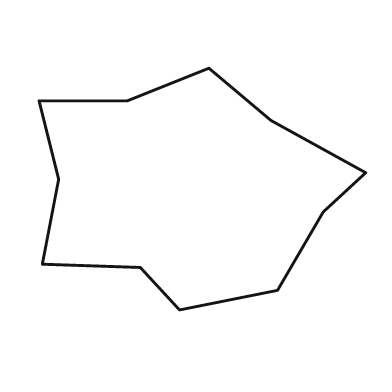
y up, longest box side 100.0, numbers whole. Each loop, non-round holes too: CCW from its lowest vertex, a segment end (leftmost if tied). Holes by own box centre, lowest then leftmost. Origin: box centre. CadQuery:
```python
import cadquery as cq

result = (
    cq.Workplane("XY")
    .moveTo(-7.0, -37.0)
    .lineTo(23.0, -31.0)
    .lineTo(37.0, -7.0)
    .lineTo(50.0, 5.0)
    .lineTo(21.0, 21.0)
    .lineTo(2.0, 37.0)
    .lineTo(-23.0, 27.0)
    .lineTo(-50.0, 27.0)
    .lineTo(-44.0, 3.0)
    .lineTo(-49.0, -23.0)
    .lineTo(-19.0, -24.0)
    .close()
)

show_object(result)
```